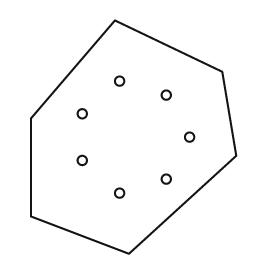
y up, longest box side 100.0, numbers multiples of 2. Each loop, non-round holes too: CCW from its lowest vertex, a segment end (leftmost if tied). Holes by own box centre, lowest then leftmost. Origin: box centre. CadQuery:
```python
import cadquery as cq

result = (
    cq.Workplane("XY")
    .moveTo(-2.0, -50.0)
    .lineTo(44.0, -8.0)
    .lineTo(38.0, 28.0)
    .lineTo(-8.0, 50.0)
    .lineTo(-44.0, 8.0)
    .lineTo(-44.0, -34.0)
    .close()
    .moveTo(-6.0, -24.0)
    .circle(2.0)
    .moveTo(14.0, -18.0)
    .circle(2.0)
    .moveTo(-22.0, -10.0)
    .circle(2.0)
    .moveTo(24.0, 0.0)
    .circle(2.0)
    .moveTo(-22.0, 10.0)
    .circle(2.0)
    .moveTo(14.0, 18.0)
    .circle(2.0)
    .moveTo(-6.0, 24.0)
    .circle(2.0)
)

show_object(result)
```